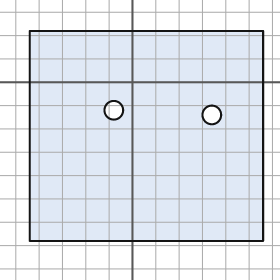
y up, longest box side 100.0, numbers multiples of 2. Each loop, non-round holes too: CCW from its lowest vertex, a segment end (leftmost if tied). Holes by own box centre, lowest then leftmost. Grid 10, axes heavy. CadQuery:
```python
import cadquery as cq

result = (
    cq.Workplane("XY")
    .moveTo(-44.0, -68.0)
    .lineTo(56.0, -68.0)
    .lineTo(56.0, 22.0)
    .lineTo(-44.0, 22.0)
    .close()
    .moveTo(34.0, -14.0)
    .circle(4.0)
    .moveTo(-8.0, -12.0)
    .circle(4.0)
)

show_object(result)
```